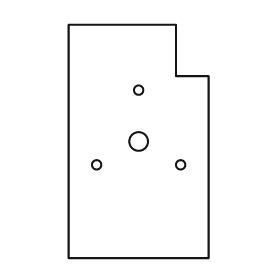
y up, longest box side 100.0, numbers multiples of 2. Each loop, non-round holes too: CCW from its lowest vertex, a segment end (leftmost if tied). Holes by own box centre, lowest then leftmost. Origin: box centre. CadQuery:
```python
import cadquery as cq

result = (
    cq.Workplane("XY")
    .moveTo(-30.0, -50.0)
    .lineTo(30.0, -50.0)
    .lineTo(30.0, 28.0)
    .lineTo(16.0, 28.0)
    .lineTo(16.0, 50.0)
    .lineTo(-30.0, 50.0)
    .close()
    .moveTo(-18.0, -10.0)
    .circle(2.0)
    .moveTo(18.0, -10.0)
    .circle(2.0)
    .moveTo(0.0, 0.0)
    .circle(4.0)
    .moveTo(0.0, 22.0)
    .circle(2.0)
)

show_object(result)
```